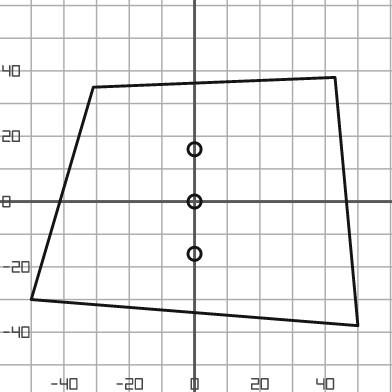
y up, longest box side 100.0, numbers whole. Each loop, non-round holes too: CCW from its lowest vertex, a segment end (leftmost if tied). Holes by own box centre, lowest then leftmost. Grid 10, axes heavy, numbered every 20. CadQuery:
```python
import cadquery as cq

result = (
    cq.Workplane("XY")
    .moveTo(50.0, -38.0)
    .lineTo(43.0, 38.0)
    .lineTo(-31.0, 35.0)
    .lineTo(-50.0, -30.0)
    .close()
    .moveTo(0.0, -16.0)
    .circle(2.0)
    .moveTo(0.0, 0.0)
    .circle(2.0)
    .moveTo(0.0, 16.0)
    .circle(2.0)
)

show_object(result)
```